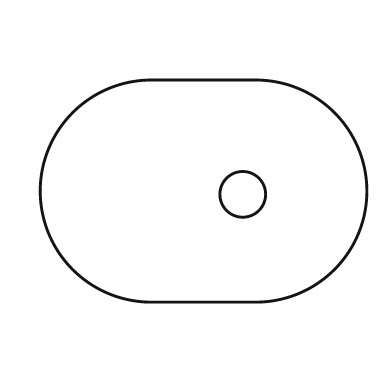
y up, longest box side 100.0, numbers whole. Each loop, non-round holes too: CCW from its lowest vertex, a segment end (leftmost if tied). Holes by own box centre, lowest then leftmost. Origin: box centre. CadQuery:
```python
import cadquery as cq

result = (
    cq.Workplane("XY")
    .moveTo(-16.0, -34.0)
    .lineTo(16.0, -34.0)
    .threePointArc((50.0, 0.0), (16.0, 34.0))
    .lineTo(-16.0, 34.0)
    .threePointArc((-50.0, 0.0), (-16.0, -34.0))
    .close()
    .moveTo(12.0, -1.0)
    .circle(7.0)
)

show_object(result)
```